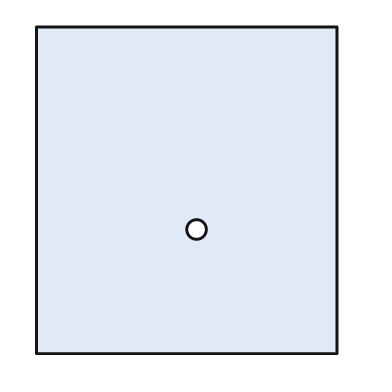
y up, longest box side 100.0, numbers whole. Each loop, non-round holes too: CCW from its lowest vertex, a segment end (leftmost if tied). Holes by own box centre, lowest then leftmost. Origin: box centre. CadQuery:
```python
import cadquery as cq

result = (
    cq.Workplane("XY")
    .moveTo(-46.0, -50.0)
    .lineTo(46.0, -50.0)
    .lineTo(46.0, 50.0)
    .lineTo(-46.0, 50.0)
    .close()
    .moveTo(3.0, -12.0)
    .circle(3.0)
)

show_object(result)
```